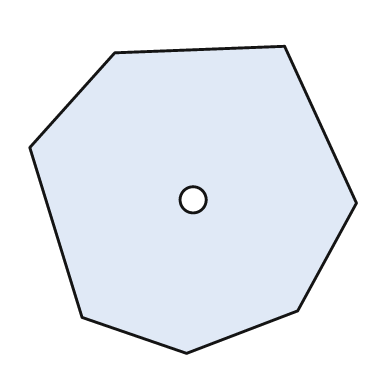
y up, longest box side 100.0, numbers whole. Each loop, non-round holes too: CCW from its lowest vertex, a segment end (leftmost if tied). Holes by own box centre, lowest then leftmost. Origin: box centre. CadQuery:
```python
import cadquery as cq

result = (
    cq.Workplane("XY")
    .moveTo(-2.0, -47.0)
    .lineTo(32.0, -34.0)
    .lineTo(50.0, -1.0)
    .lineTo(28.0, 47.0)
    .lineTo(-24.0, 45.0)
    .lineTo(-50.0, 16.0)
    .lineTo(-34.0, -36.0)
    .close()
    .moveTo(0.0, 0.0)
    .circle(4.0)
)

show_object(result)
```